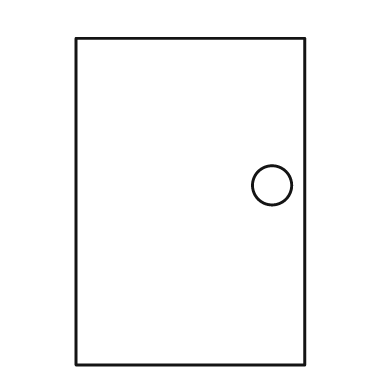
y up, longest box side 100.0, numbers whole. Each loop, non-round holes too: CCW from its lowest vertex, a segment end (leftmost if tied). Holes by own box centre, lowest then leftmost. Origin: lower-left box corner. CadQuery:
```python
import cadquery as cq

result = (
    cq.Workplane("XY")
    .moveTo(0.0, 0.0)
    .lineTo(70.0, 0.0)
    .lineTo(70.0, 100.0)
    .lineTo(0.0, 100.0)
    .close()
    .moveTo(60.0, 55.0)
    .circle(6.0)
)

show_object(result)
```